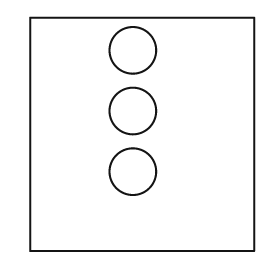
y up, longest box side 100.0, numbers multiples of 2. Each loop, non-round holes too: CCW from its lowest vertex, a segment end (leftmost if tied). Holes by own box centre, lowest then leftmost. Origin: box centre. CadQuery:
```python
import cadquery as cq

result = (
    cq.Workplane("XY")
    .moveTo(-48.0, -50.0)
    .lineTo(48.0, -50.0)
    .lineTo(48.0, 50.0)
    .lineTo(-48.0, 50.0)
    .close()
    .moveTo(-4.0, -16.0)
    .circle(10.0)
    .moveTo(-4.0, 10.0)
    .circle(10.0)
    .moveTo(-4.0, 36.0)
    .circle(10.0)
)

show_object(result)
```